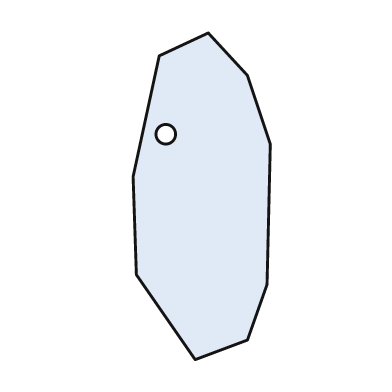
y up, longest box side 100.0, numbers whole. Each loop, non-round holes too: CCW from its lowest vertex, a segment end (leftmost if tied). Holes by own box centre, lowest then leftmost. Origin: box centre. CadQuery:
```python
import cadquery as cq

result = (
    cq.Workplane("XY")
    .moveTo(-2.0, -50.0)
    .lineTo(14.0, -44.0)
    .lineTo(20.0, -27.0)
    .lineTo(21.0, 16.0)
    .lineTo(14.0, 37.0)
    .lineTo(2.0, 50.0)
    .lineTo(-13.0, 43.0)
    .lineTo(-21.0, 6.0)
    .lineTo(-20.0, -24.0)
    .close()
    .moveTo(-11.0, 19.0)
    .circle(3.0)
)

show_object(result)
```